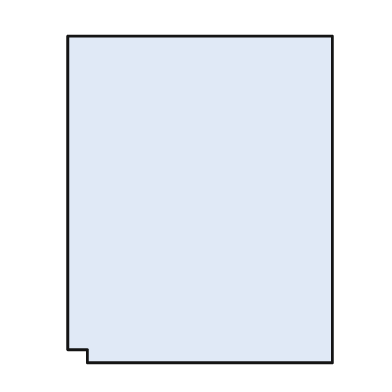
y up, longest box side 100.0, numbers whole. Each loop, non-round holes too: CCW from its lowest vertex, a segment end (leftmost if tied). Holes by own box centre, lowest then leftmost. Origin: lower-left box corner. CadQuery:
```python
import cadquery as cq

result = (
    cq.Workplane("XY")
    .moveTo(6.0, 0.0)
    .lineTo(81.0, 0.0)
    .lineTo(81.0, 100.0)
    .lineTo(0.0, 100.0)
    .lineTo(0.0, 4.0)
    .lineTo(6.0, 4.0)
    .close()
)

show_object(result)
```